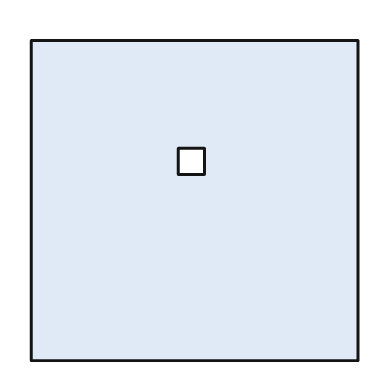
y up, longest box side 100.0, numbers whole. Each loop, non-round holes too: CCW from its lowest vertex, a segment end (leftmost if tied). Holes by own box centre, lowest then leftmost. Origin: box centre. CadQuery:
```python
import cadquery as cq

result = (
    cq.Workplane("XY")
    .moveTo(-50.0, -49.0)
    .lineTo(50.0, -49.0)
    .lineTo(50.0, 49.0)
    .lineTo(-50.0, 49.0)
    .close()
    .moveTo(-5.0, 8.0)
    .lineTo(3.0, 8.0)
    .lineTo(3.0, 16.0)
    .lineTo(-5.0, 16.0)
    .close()
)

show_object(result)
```